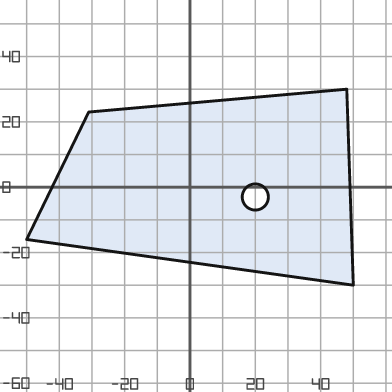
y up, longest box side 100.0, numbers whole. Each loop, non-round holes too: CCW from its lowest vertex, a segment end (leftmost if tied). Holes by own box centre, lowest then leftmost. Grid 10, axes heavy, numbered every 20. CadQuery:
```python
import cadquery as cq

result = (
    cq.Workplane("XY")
    .moveTo(50.0, -30.0)
    .lineTo(48.0, 30.0)
    .lineTo(-31.0, 23.0)
    .lineTo(-50.0, -16.0)
    .close()
    .moveTo(20.0, -3.0)
    .circle(4.0)
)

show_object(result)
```